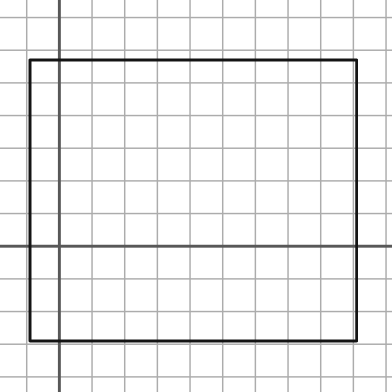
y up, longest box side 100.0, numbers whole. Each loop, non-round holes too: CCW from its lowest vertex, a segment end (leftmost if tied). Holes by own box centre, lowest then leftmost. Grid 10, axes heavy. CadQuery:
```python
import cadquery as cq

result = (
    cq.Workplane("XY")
    .moveTo(-9.0, -29.0)
    .lineTo(91.0, -29.0)
    .lineTo(91.0, 57.0)
    .lineTo(-9.0, 57.0)
    .close()
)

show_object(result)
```